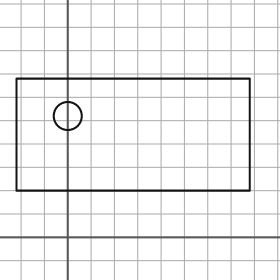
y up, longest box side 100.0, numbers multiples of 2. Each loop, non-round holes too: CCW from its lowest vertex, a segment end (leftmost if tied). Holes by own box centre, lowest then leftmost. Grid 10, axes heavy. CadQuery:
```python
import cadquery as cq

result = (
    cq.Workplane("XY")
    .moveTo(-22.0, 20.0)
    .lineTo(78.0, 20.0)
    .lineTo(78.0, 68.0)
    .lineTo(-22.0, 68.0)
    .close()
    .moveTo(0.0, 52.0)
    .circle(6.0)
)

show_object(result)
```